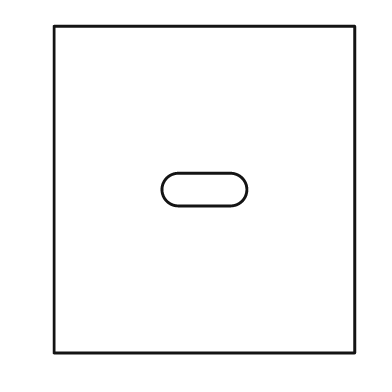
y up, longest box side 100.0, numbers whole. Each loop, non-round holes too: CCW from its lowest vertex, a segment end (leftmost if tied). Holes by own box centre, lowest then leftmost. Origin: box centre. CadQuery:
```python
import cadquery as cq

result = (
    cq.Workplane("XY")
    .moveTo(-46.0, -50.0)
    .lineTo(46.0, -50.0)
    .lineTo(46.0, 50.0)
    .lineTo(-46.0, 50.0)
    .close()
    .moveTo(-8.0, -5.0)
    .lineTo(8.0, -5.0)
    .threePointArc((13.0, 0.0), (8.0, 5.0))
    .lineTo(-8.0, 5.0)
    .threePointArc((-13.0, 0.0), (-8.0, -5.0))
    .close()
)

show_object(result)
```